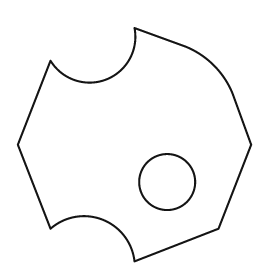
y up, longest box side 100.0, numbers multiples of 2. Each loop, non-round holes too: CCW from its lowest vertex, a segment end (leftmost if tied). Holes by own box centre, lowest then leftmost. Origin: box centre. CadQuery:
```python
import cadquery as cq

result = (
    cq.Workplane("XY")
    .moveTo(0.0, -50.0)
    .lineTo(36.0, -36.0)
    .lineTo(50.0, 0.0)
    .lineTo(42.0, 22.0)
    .threePointArc((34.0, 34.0), (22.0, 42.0))
    .lineTo(0.0, 50.0)
    .threePointArc((-12.0, 28.0), (-36.0, 36.0))
    .lineTo(-50.0, 0.0)
    .lineTo(-36.0, -36.0)
    .threePointArc((-14.0, -32.0), (0.0, -50.0))
    .close()
    .moveTo(14.0, -16.0)
    .circle(12.0)
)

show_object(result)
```